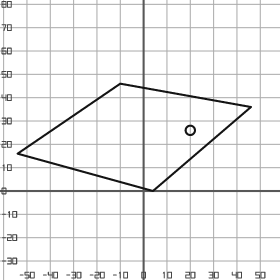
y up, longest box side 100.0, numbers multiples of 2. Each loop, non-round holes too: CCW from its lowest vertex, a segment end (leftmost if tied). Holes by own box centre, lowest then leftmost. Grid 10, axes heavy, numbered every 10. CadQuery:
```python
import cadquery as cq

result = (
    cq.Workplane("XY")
    .moveTo(4.0, 0.0)
    .lineTo(46.0, 36.0)
    .lineTo(-10.0, 46.0)
    .lineTo(-54.0, 16.0)
    .close()
    .moveTo(20.0, 26.0)
    .circle(2.0)
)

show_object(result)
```